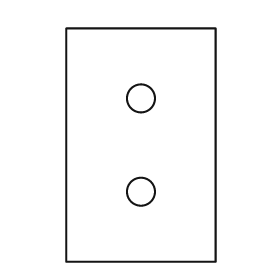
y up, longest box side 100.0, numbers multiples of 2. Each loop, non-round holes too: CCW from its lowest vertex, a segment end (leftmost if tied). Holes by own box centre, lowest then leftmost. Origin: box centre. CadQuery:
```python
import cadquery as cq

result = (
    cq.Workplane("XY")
    .moveTo(-32.0, -50.0)
    .lineTo(32.0, -50.0)
    .lineTo(32.0, 50.0)
    .lineTo(-32.0, 50.0)
    .close()
    .moveTo(0.0, -20.0)
    .circle(6.0)
    .moveTo(0.0, 20.0)
    .circle(6.0)
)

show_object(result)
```